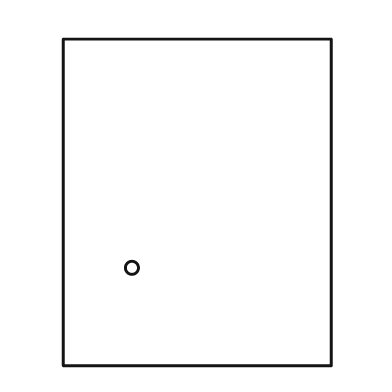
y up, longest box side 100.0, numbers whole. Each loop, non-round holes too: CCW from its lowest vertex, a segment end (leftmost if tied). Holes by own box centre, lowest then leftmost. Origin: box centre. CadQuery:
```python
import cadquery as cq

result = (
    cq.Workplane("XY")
    .moveTo(-41.0, -50.0)
    .lineTo(41.0, -50.0)
    .lineTo(41.0, 50.0)
    .lineTo(-41.0, 50.0)
    .close()
    .moveTo(-20.0, -20.0)
    .circle(2.0)
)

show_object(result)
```